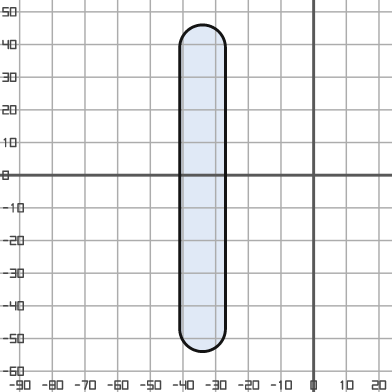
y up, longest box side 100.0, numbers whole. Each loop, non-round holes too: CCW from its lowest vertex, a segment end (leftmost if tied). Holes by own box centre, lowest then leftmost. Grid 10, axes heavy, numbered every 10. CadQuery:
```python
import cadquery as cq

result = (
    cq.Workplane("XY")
    .moveTo(-41.0, -47.0)
    .threePointArc((-34.0, -54.0), (-27.0, -47.0))
    .lineTo(-27.0, 39.0)
    .threePointArc((-34.0, 46.0), (-41.0, 39.0))
    .close()
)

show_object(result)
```